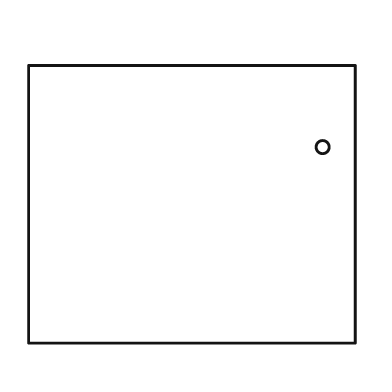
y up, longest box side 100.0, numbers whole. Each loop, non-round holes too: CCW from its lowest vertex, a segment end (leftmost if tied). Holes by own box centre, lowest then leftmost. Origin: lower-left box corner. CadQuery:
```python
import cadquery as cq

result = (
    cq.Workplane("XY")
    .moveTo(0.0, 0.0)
    .lineTo(100.0, 0.0)
    .lineTo(100.0, 85.0)
    .lineTo(0.0, 85.0)
    .close()
    .moveTo(90.0, 60.0)
    .circle(2.0)
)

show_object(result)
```